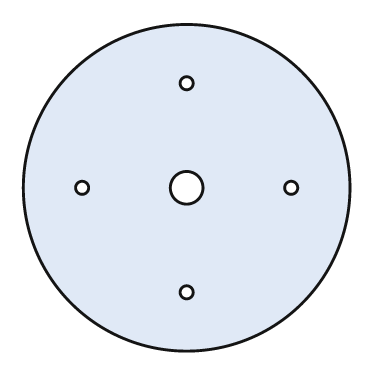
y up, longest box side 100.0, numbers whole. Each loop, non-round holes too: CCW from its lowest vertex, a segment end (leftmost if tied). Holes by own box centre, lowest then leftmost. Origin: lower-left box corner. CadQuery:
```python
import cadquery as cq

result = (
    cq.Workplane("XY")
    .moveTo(50.0, 50.0)
    .circle(50.0)
    .moveTo(50.0, 18.0)
    .circle(2.0)
    .moveTo(18.0, 50.0)
    .circle(2.0)
    .moveTo(50.0, 50.0)
    .circle(5.0)
    .moveTo(82.0, 50.0)
    .circle(2.0)
    .moveTo(50.0, 82.0)
    .circle(2.0)
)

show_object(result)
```